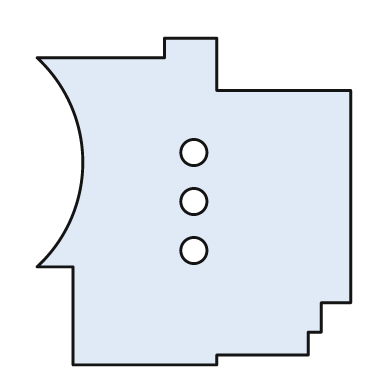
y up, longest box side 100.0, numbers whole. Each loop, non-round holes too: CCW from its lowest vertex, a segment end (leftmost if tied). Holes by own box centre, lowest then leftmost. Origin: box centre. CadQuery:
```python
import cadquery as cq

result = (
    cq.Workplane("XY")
    .moveTo(-37.0, -50.0)
    .lineTo(7.0, -50.0)
    .lineTo(7.0, -47.0)
    .lineTo(35.0, -47.0)
    .lineTo(35.0, -40.0)
    .lineTo(39.0, -40.0)
    .lineTo(39.0, -31.0)
    .lineTo(48.0, -31.0)
    .lineTo(48.0, 34.0)
    .lineTo(7.0, 34.0)
    .lineTo(7.0, 50.0)
    .lineTo(-9.0, 50.0)
    .lineTo(-9.0, 44.0)
    .lineTo(-48.0, 44.0)
    .threePointArc((-34.0, 12.0), (-48.0, -20.0))
    .lineTo(-37.0, -20.0)
    .close()
    .moveTo(0.0, -15.0)
    .circle(4.0)
    .moveTo(0.0, 0.0)
    .circle(4.0)
    .moveTo(0.0, 15.0)
    .circle(4.0)
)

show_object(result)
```